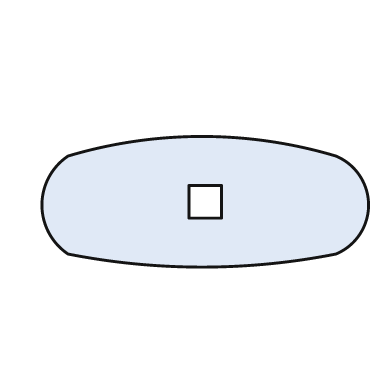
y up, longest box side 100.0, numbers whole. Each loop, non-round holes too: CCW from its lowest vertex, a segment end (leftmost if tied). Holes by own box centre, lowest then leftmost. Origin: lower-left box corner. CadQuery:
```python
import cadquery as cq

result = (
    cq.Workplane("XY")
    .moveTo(8.0, 4.0)
    .threePointArc((49.0, 0.0), (90.0, 4.0))
    .threePointArc((100.0, 19.0), (90.0, 34.0))
    .threePointArc((49.0, 40.0), (8.0, 34.0))
    .threePointArc((0.0, 19.0), (8.0, 4.0))
    .close()
    .moveTo(45.0, 15.0)
    .lineTo(55.0, 15.0)
    .lineTo(55.0, 25.0)
    .lineTo(45.0, 25.0)
    .close()
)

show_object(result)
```